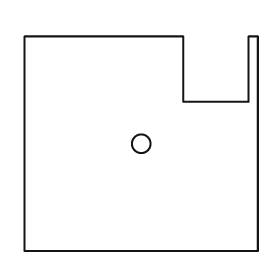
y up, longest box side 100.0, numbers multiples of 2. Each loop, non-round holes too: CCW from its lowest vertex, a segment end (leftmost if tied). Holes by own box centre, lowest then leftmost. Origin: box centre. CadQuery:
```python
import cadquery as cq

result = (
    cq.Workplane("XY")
    .moveTo(-50.0, -46.0)
    .lineTo(50.0, -46.0)
    .lineTo(50.0, 46.0)
    .lineTo(46.0, 46.0)
    .lineTo(46.0, 18.0)
    .lineTo(18.0, 18.0)
    .lineTo(18.0, 46.0)
    .lineTo(-50.0, 46.0)
    .close()
    .moveTo(0.0, 0.0)
    .circle(4.0)
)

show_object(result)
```